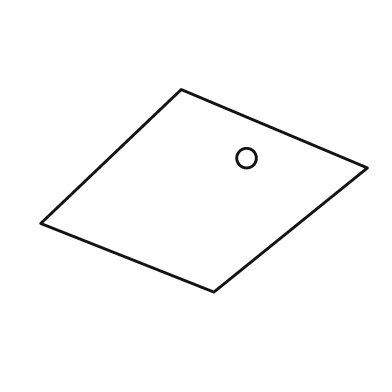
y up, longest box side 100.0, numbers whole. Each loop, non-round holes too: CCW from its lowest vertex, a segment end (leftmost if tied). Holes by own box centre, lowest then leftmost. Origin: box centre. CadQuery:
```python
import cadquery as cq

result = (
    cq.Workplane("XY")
    .moveTo(3.0, -31.0)
    .lineTo(50.0, 7.0)
    .lineTo(-7.0, 31.0)
    .lineTo(-50.0, -10.0)
    .close()
    .moveTo(13.0, 10.0)
    .circle(3.0)
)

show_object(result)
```